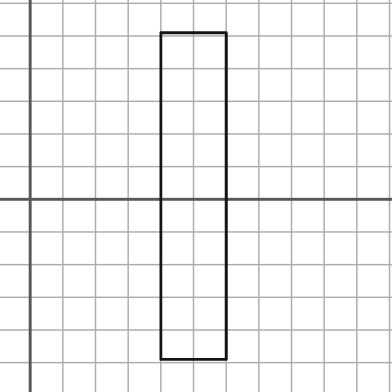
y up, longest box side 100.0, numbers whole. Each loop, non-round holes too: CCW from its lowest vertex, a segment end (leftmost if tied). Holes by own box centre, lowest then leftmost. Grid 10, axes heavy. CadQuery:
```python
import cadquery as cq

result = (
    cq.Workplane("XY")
    .moveTo(40.0, -49.0)
    .lineTo(60.0, -49.0)
    .lineTo(60.0, 51.0)
    .lineTo(40.0, 51.0)
    .close()
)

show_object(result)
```